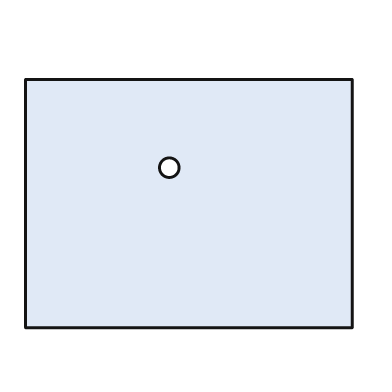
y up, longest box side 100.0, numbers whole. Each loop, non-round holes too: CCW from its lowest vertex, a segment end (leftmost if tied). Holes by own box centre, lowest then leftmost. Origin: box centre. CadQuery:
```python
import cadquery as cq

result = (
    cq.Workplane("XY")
    .moveTo(-50.0, -38.0)
    .lineTo(50.0, -38.0)
    .lineTo(50.0, 38.0)
    .lineTo(-50.0, 38.0)
    .close()
    .moveTo(-6.0, 11.0)
    .circle(3.0)
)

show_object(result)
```